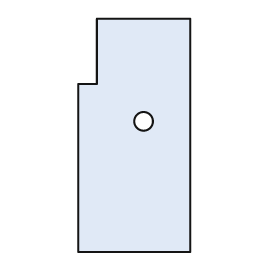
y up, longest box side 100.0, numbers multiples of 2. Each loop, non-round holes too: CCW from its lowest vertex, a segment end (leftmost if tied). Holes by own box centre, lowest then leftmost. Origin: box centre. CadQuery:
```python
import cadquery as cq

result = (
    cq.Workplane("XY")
    .moveTo(-24.0, -50.0)
    .lineTo(24.0, -50.0)
    .lineTo(24.0, 50.0)
    .lineTo(-16.0, 50.0)
    .lineTo(-16.0, 22.0)
    .lineTo(-24.0, 22.0)
    .close()
    .moveTo(4.0, 6.0)
    .circle(4.0)
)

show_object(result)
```